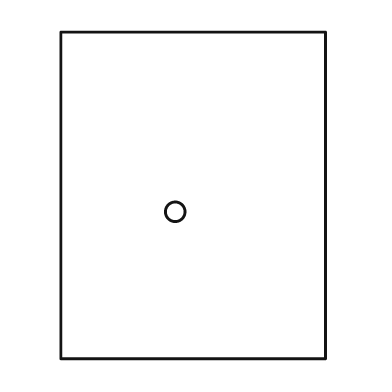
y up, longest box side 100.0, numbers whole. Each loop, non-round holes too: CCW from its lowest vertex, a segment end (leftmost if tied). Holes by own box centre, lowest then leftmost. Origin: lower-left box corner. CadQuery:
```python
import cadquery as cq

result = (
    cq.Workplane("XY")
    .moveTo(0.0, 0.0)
    .lineTo(81.0, 0.0)
    .lineTo(81.0, 100.0)
    .lineTo(0.0, 100.0)
    .close()
    .moveTo(35.0, 45.0)
    .circle(3.0)
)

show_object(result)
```